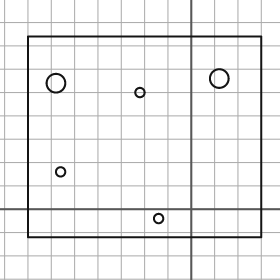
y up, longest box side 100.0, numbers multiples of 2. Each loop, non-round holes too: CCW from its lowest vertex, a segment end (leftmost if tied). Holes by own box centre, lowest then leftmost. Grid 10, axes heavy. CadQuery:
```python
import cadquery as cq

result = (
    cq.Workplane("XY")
    .moveTo(-70.0, -12.0)
    .lineTo(30.0, -12.0)
    .lineTo(30.0, 74.0)
    .lineTo(-70.0, 74.0)
    .close()
    .moveTo(-14.0, -4.0)
    .circle(2.0)
    .moveTo(-56.0, 16.0)
    .circle(2.0)
    .moveTo(-22.0, 50.0)
    .circle(2.0)
    .moveTo(-58.0, 54.0)
    .circle(4.0)
    .moveTo(12.0, 56.0)
    .circle(4.0)
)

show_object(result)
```